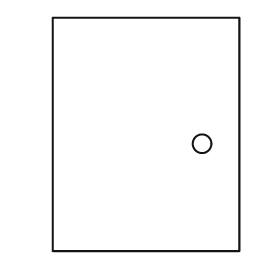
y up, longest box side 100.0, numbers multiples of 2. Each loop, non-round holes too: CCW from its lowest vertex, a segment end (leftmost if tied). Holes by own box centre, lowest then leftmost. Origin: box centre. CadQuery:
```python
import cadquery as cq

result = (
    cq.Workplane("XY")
    .moveTo(-40.0, -50.0)
    .lineTo(40.0, -50.0)
    .lineTo(40.0, 50.0)
    .lineTo(-40.0, 50.0)
    .close()
    .moveTo(24.0, -4.0)
    .circle(4.0)
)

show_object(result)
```